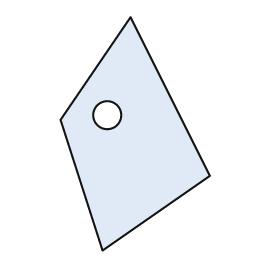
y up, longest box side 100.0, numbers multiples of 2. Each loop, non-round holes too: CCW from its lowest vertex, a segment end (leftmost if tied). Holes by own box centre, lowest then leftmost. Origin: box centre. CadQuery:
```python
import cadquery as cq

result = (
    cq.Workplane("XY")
    .moveTo(-14.0, -50.0)
    .lineTo(32.0, -18.0)
    .lineTo(-2.0, 50.0)
    .lineTo(-32.0, 6.0)
    .close()
    .moveTo(-12.0, 8.0)
    .circle(6.0)
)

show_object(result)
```